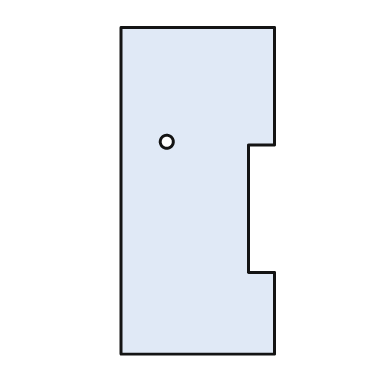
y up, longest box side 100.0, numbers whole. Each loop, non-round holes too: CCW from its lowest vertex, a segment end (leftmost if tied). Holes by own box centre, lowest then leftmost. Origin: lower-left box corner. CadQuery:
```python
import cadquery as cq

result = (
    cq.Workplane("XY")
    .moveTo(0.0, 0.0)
    .lineTo(47.0, 0.0)
    .lineTo(47.0, 25.0)
    .lineTo(39.0, 25.0)
    .lineTo(39.0, 64.0)
    .lineTo(47.0, 64.0)
    .lineTo(47.0, 100.0)
    .lineTo(0.0, 100.0)
    .close()
    .moveTo(14.0, 65.0)
    .circle(2.0)
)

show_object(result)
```